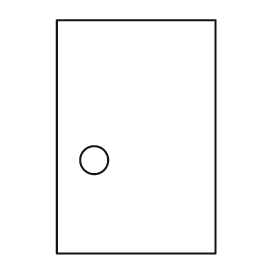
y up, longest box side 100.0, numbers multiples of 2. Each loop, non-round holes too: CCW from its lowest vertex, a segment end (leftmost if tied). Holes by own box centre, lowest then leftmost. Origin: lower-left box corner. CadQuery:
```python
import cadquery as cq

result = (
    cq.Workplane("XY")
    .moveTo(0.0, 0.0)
    .lineTo(68.0, 0.0)
    .lineTo(68.0, 100.0)
    .lineTo(0.0, 100.0)
    .close()
    .moveTo(16.0, 40.0)
    .circle(6.0)
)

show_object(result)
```